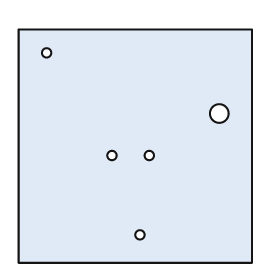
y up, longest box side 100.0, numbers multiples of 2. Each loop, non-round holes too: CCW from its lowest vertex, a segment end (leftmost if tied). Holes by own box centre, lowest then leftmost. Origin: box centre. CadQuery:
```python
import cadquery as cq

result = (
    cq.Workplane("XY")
    .moveTo(-50.0, -50.0)
    .lineTo(50.0, -50.0)
    .lineTo(50.0, 50.0)
    .lineTo(-50.0, 50.0)
    .close()
    .moveTo(2.0, -38.0)
    .circle(2.0)
    .moveTo(-10.0, -4.0)
    .circle(2.0)
    .moveTo(6.0, -4.0)
    .circle(2.0)
    .moveTo(36.0, 14.0)
    .circle(4.0)
    .moveTo(-38.0, 40.0)
    .circle(2.0)
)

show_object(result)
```